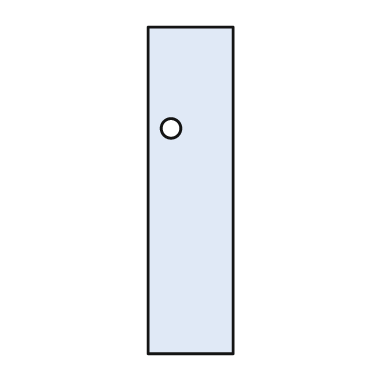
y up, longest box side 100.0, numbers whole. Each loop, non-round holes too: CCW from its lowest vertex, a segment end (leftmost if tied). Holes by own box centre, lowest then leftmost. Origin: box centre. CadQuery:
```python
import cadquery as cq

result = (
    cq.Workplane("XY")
    .moveTo(-13.0, -50.0)
    .lineTo(13.0, -50.0)
    .lineTo(13.0, 50.0)
    .lineTo(-13.0, 50.0)
    .close()
    .moveTo(-6.0, 19.0)
    .circle(3.0)
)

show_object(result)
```